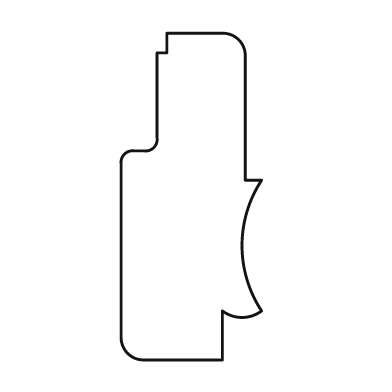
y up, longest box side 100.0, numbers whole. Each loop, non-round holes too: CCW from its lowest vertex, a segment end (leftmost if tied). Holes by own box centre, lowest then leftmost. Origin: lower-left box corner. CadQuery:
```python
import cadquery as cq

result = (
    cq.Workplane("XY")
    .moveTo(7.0, 0.0)
    .lineTo(31.0, 0.0)
    .lineTo(31.0, 15.0)
    .threePointArc((37.0, 13.0), (43.0, 15.0))
    .threePointArc((37.0, 35.0), (43.0, 55.0))
    .lineTo(38.0, 55.0)
    .lineTo(38.0, 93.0)
    .threePointArc((36.0, 98.0), (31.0, 100.0))
    .lineTo(14.0, 100.0)
    .lineTo(14.0, 94.0)
    .lineTo(11.0, 94.0)
    .lineTo(11.0, 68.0)
    .threePointArc((10.0, 65.0), (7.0, 64.0))
    .lineTo(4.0, 64.0)
    .threePointArc((1.0, 63.0), (0.0, 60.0))
    .lineTo(0.0, 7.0)
    .threePointArc((2.0, 2.0), (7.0, 0.0))
    .close()
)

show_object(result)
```